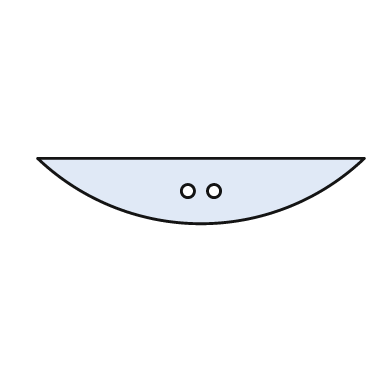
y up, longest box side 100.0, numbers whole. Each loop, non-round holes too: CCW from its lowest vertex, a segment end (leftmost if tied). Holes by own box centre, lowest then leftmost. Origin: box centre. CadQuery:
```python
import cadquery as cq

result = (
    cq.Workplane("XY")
    .moveTo(-50.0, 10.0)
    .threePointArc((0.0, -10.0), (50.0, 10.0))
    .close()
    .moveTo(-4.0, 0.0)
    .circle(2.0)
    .moveTo(4.0, 0.0)
    .circle(2.0)
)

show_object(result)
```